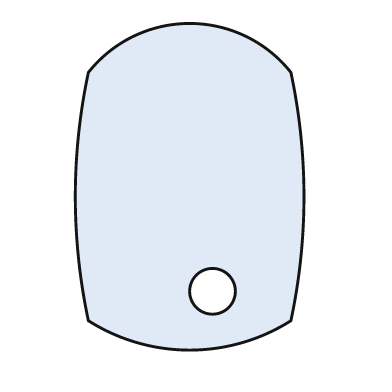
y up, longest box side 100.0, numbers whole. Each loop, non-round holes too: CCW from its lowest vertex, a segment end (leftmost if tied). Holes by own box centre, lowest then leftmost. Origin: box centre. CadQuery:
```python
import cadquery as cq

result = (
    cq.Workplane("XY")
    .moveTo(-31.0, -41.0)
    .threePointArc((0.0, -50.0), (31.0, -41.0))
    .threePointArc((35.0, -3.0), (31.0, 35.0))
    .threePointArc((0.0, 50.0), (-31.0, 35.0))
    .threePointArc((-35.0, -3.0), (-31.0, -41.0))
    .close()
    .moveTo(7.0, -32.0)
    .circle(7.0)
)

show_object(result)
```